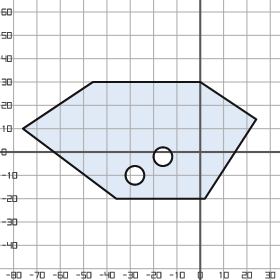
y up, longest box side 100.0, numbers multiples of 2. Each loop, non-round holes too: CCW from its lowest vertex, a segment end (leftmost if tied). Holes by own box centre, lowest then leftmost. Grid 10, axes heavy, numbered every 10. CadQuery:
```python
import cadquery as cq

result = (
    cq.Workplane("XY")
    .moveTo(-36.0, -20.0)
    .lineTo(2.0, -20.0)
    .lineTo(24.0, 14.0)
    .lineTo(0.0, 30.0)
    .lineTo(-46.0, 30.0)
    .lineTo(-76.0, 10.0)
    .close()
    .moveTo(-28.0, -10.0)
    .circle(4.0)
    .moveTo(-16.0, -2.0)
    .circle(4.0)
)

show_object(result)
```